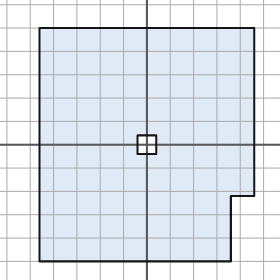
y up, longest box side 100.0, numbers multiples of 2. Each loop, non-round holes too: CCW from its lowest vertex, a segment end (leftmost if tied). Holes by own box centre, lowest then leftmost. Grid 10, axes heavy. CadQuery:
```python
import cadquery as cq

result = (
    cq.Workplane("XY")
    .moveTo(-46.0, -50.0)
    .lineTo(36.0, -50.0)
    .lineTo(36.0, -22.0)
    .lineTo(46.0, -22.0)
    .lineTo(46.0, 50.0)
    .lineTo(-46.0, 50.0)
    .close()
    .moveTo(-4.0, -4.0)
    .lineTo(4.0, -4.0)
    .lineTo(4.0, 4.0)
    .lineTo(-4.0, 4.0)
    .close()
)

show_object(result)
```